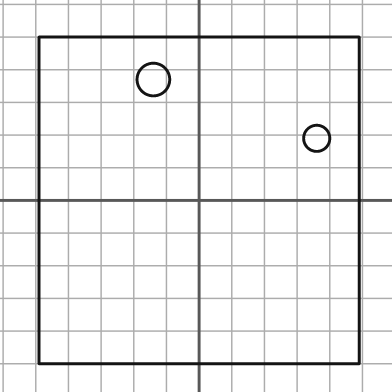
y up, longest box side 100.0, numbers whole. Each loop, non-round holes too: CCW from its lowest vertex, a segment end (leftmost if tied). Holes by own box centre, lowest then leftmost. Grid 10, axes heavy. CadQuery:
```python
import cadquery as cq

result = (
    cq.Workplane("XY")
    .moveTo(-49.0, -50.0)
    .lineTo(49.0, -50.0)
    .lineTo(49.0, 50.0)
    .lineTo(-49.0, 50.0)
    .close()
    .moveTo(36.0, 19.0)
    .circle(4.0)
    .moveTo(-14.0, 37.0)
    .circle(5.0)
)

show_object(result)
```